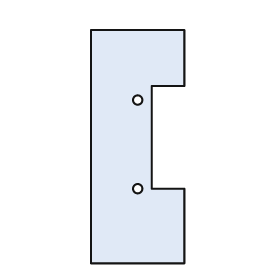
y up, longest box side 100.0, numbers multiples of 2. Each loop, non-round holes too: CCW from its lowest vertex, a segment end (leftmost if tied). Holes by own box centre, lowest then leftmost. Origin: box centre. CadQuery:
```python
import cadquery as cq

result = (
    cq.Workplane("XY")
    .moveTo(-20.0, -50.0)
    .lineTo(20.0, -50.0)
    .lineTo(20.0, -18.0)
    .lineTo(6.0, -18.0)
    .lineTo(6.0, 26.0)
    .lineTo(20.0, 26.0)
    .lineTo(20.0, 50.0)
    .lineTo(-20.0, 50.0)
    .close()
    .moveTo(0.0, -18.0)
    .circle(2.0)
    .moveTo(0.0, 20.0)
    .circle(2.0)
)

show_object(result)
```